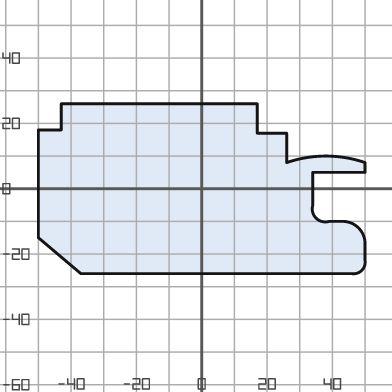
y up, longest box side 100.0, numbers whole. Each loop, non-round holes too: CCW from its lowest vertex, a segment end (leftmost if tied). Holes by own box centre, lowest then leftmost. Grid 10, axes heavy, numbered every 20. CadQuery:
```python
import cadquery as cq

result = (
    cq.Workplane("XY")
    .moveTo(-37.0, -26.0)
    .lineTo(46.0, -26.0)
    .threePointArc((49.0, -25.0), (50.0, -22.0))
    .lineTo(50.0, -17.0)
    .threePointArc((48.0, -12.0), (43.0, -10.0))
    .lineTo(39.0, -10.0)
    .threePointArc((35.0, -9.0), (34.0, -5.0))
    .lineTo(34.0, 5.0)
    .lineTo(50.0, 5.0)
    .lineTo(50.0, 8.0)
    .threePointArc((38.0, 10.0), (26.0, 8.0))
    .lineTo(26.0, 17.0)
    .lineTo(17.0, 17.0)
    .lineTo(17.0, 26.0)
    .lineTo(-43.0, 26.0)
    .lineTo(-43.0, 18.0)
    .lineTo(-50.0, 18.0)
    .lineTo(-50.0, -15.0)
    .close()
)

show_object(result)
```